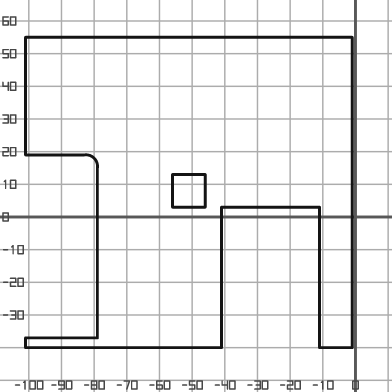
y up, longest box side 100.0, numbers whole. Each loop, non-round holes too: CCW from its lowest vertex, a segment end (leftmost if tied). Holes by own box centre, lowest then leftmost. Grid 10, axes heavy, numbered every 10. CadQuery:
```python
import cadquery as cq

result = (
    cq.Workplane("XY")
    .moveTo(-101.0, -40.0)
    .lineTo(-41.0, -40.0)
    .lineTo(-41.0, 3.0)
    .lineTo(-11.0, 3.0)
    .lineTo(-11.0, -40.0)
    .lineTo(-1.0, -40.0)
    .lineTo(-1.0, 55.0)
    .lineTo(-101.0, 55.0)
    .lineTo(-101.0, 19.0)
    .lineTo(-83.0, 19.0)
    .threePointArc((-80.0, 18.0), (-79.0, 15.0))
    .lineTo(-79.0, -37.0)
    .lineTo(-101.0, -37.0)
    .close()
    .moveTo(-56.0, 3.0)
    .lineTo(-46.0, 3.0)
    .lineTo(-46.0, 13.0)
    .lineTo(-56.0, 13.0)
    .close()
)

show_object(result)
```